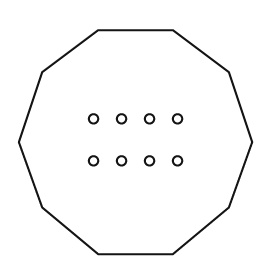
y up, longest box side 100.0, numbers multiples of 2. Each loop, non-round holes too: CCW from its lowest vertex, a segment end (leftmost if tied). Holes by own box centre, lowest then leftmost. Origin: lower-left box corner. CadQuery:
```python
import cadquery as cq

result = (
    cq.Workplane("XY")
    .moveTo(34.0, 0.0)
    .lineTo(66.0, 0.0)
    .lineTo(90.0, 20.0)
    .lineTo(100.0, 48.0)
    .lineTo(90.0, 78.0)
    .lineTo(66.0, 96.0)
    .lineTo(34.0, 96.0)
    .lineTo(10.0, 78.0)
    .lineTo(0.0, 48.0)
    .lineTo(10.0, 20.0)
    .close()
    .moveTo(32.0, 40.0)
    .circle(2.0)
    .moveTo(44.0, 40.0)
    .circle(2.0)
    .moveTo(56.0, 40.0)
    .circle(2.0)
    .moveTo(68.0, 40.0)
    .circle(2.0)
    .moveTo(32.0, 58.0)
    .circle(2.0)
    .moveTo(44.0, 58.0)
    .circle(2.0)
    .moveTo(56.0, 58.0)
    .circle(2.0)
    .moveTo(68.0, 58.0)
    .circle(2.0)
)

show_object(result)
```